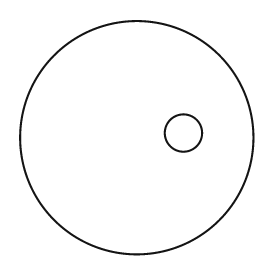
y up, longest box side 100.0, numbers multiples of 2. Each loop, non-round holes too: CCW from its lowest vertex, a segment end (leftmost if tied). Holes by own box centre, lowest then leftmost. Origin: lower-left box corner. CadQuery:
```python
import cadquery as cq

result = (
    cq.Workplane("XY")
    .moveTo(50.0, 50.0)
    .circle(50.0)
    .moveTo(70.0, 52.0)
    .circle(8.0)
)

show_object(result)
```